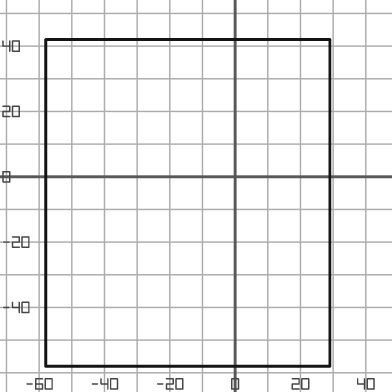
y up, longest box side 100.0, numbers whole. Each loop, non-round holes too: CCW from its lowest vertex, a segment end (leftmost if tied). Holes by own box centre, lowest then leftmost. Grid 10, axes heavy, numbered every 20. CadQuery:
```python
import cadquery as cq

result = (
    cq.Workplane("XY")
    .moveTo(-58.0, -58.0)
    .lineTo(29.0, -58.0)
    .lineTo(29.0, 42.0)
    .lineTo(-58.0, 42.0)
    .close()
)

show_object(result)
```